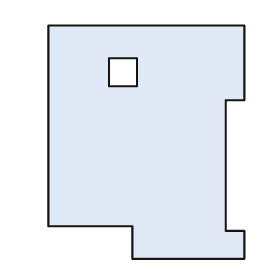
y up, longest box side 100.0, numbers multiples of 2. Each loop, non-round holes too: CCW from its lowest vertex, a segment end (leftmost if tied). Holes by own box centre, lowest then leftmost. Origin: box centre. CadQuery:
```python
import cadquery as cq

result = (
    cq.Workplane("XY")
    .moveTo(-6.0, -50.0)
    .lineTo(42.0, -50.0)
    .lineTo(42.0, -38.0)
    .lineTo(34.0, -38.0)
    .lineTo(34.0, 18.0)
    .lineTo(42.0, 18.0)
    .lineTo(42.0, 50.0)
    .lineTo(-42.0, 50.0)
    .lineTo(-42.0, -36.0)
    .lineTo(-6.0, -36.0)
    .close()
    .moveTo(-16.0, 24.0)
    .lineTo(-4.0, 24.0)
    .lineTo(-4.0, 36.0)
    .lineTo(-16.0, 36.0)
    .close()
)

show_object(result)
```